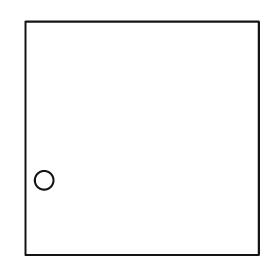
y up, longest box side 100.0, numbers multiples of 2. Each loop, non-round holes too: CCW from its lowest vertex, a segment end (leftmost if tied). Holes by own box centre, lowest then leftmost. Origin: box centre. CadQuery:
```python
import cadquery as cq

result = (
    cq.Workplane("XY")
    .moveTo(-50.0, -50.0)
    .lineTo(50.0, -50.0)
    .lineTo(50.0, 50.0)
    .lineTo(-50.0, 50.0)
    .close()
    .moveTo(-42.0, -18.0)
    .circle(4.0)
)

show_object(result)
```